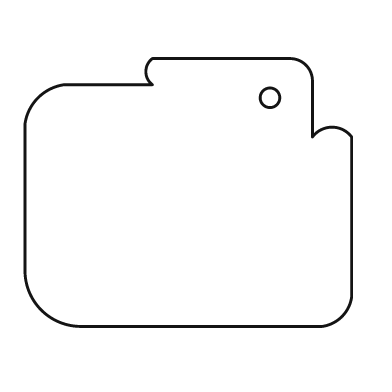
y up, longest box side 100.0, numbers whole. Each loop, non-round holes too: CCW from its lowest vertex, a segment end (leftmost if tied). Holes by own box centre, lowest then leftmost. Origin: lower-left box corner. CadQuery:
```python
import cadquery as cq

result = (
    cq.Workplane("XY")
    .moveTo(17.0, 0.0)
    .lineTo(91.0, 0.0)
    .threePointArc((97.0, 3.0), (100.0, 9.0))
    .lineTo(100.0, 58.0)
    .threePointArc((94.0, 61.0), (88.0, 58.0))
    .lineTo(88.0, 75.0)
    .threePointArc((86.0, 80.0), (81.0, 82.0))
    .lineTo(39.0, 82.0)
    .threePointArc((37.0, 78.0), (39.0, 74.0))
    .lineTo(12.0, 74.0)
    .threePointArc((4.0, 70.0), (0.0, 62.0))
    .lineTo(0.0, 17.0)
    .threePointArc((5.0, 5.0), (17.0, 0.0))
    .close()
    .moveTo(75.0, 70.0)
    .circle(3.0)
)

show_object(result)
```